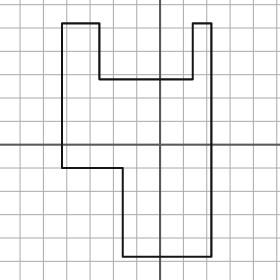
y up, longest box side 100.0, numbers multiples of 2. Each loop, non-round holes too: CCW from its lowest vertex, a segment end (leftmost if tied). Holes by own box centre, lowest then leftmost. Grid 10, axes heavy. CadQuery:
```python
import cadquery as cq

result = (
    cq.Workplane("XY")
    .moveTo(-16.0, -48.0)
    .lineTo(22.0, -48.0)
    .lineTo(22.0, 52.0)
    .lineTo(14.0, 52.0)
    .lineTo(14.0, 28.0)
    .lineTo(-26.0, 28.0)
    .lineTo(-26.0, 52.0)
    .lineTo(-42.0, 52.0)
    .lineTo(-42.0, -10.0)
    .lineTo(-16.0, -10.0)
    .close()
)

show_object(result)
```